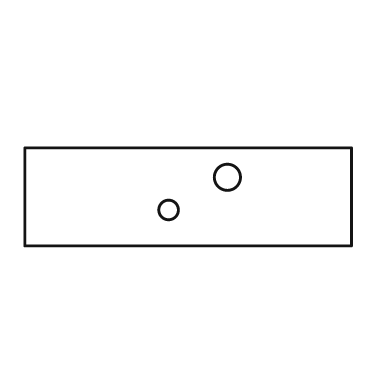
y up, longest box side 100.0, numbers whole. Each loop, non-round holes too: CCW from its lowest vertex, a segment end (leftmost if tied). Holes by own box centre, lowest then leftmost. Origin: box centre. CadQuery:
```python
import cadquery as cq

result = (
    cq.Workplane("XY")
    .moveTo(-50.0, -15.0)
    .lineTo(50.0, -15.0)
    .lineTo(50.0, 15.0)
    .lineTo(-50.0, 15.0)
    .close()
    .moveTo(-6.0, -4.0)
    .circle(3.0)
    .moveTo(12.0, 6.0)
    .circle(4.0)
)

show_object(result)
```